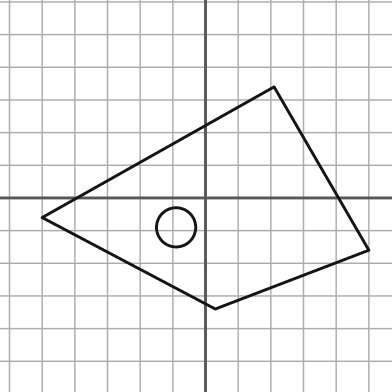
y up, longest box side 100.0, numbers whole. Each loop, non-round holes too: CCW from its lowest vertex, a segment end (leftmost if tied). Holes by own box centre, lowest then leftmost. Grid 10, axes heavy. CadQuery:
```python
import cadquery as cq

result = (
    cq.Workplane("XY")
    .moveTo(3.0, -34.0)
    .lineTo(50.0, -16.0)
    .lineTo(21.0, 34.0)
    .lineTo(-50.0, -6.0)
    .close()
    .moveTo(-9.0, -9.0)
    .circle(6.0)
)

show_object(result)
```